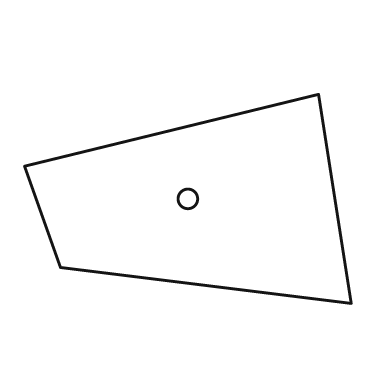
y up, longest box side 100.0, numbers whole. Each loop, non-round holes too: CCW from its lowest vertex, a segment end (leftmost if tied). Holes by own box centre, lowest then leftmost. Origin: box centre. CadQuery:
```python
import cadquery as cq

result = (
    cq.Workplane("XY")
    .moveTo(50.0, -32.0)
    .lineTo(40.0, 32.0)
    .lineTo(-50.0, 10.0)
    .lineTo(-39.0, -21.0)
    .close()
    .moveTo(0.0, 0.0)
    .circle(3.0)
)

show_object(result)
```